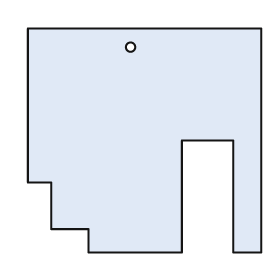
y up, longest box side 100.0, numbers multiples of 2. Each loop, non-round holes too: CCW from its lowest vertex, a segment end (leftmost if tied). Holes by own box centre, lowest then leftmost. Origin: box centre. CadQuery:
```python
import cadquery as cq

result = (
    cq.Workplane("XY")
    .moveTo(-24.0, -48.0)
    .lineTo(16.0, -48.0)
    .lineTo(16.0, 0.0)
    .lineTo(38.0, 0.0)
    .lineTo(38.0, -48.0)
    .lineTo(50.0, -48.0)
    .lineTo(50.0, 48.0)
    .lineTo(-50.0, 48.0)
    .lineTo(-50.0, -18.0)
    .lineTo(-40.0, -18.0)
    .lineTo(-40.0, -38.0)
    .lineTo(-24.0, -38.0)
    .close()
    .moveTo(-6.0, 40.0)
    .circle(2.0)
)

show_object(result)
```